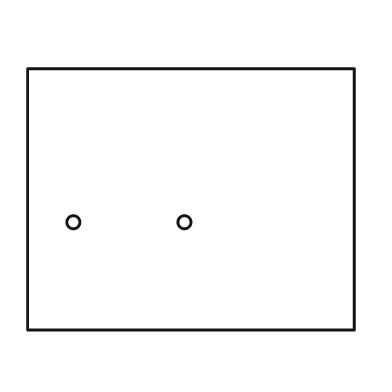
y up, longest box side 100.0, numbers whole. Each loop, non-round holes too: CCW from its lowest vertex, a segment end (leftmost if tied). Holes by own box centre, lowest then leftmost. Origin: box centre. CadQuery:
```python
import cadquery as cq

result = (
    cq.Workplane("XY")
    .moveTo(-50.0, -40.0)
    .lineTo(50.0, -40.0)
    .lineTo(50.0, 40.0)
    .lineTo(-50.0, 40.0)
    .close()
    .moveTo(-36.0, -7.0)
    .circle(2.0)
    .moveTo(-2.0, -7.0)
    .circle(2.0)
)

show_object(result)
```